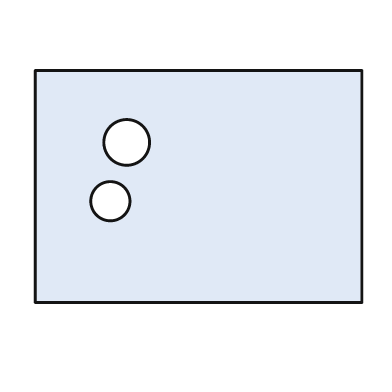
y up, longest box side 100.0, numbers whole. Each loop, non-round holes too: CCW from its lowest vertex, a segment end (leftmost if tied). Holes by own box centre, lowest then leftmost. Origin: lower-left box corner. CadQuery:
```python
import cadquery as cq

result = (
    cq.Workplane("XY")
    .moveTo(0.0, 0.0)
    .lineTo(100.0, 0.0)
    .lineTo(100.0, 71.0)
    .lineTo(0.0, 71.0)
    .close()
    .moveTo(23.0, 31.0)
    .circle(6.0)
    .moveTo(28.0, 49.0)
    .circle(7.0)
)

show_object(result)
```